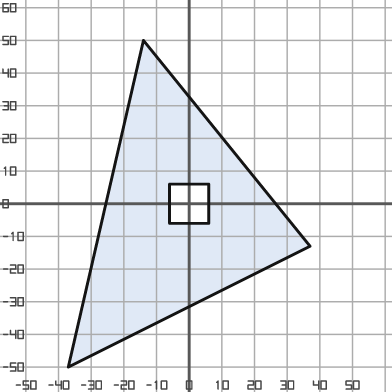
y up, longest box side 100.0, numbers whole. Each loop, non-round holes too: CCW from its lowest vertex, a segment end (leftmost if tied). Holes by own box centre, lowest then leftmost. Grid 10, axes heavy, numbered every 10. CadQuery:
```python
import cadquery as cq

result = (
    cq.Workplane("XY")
    .moveTo(-37.0, -50.0)
    .lineTo(37.0, -13.0)
    .lineTo(-14.0, 50.0)
    .close()
    .moveTo(-6.0, -6.0)
    .lineTo(6.0, -6.0)
    .lineTo(6.0, 6.0)
    .lineTo(-6.0, 6.0)
    .close()
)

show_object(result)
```